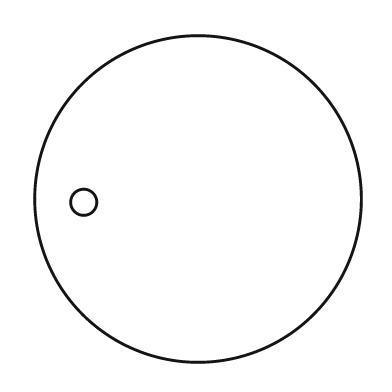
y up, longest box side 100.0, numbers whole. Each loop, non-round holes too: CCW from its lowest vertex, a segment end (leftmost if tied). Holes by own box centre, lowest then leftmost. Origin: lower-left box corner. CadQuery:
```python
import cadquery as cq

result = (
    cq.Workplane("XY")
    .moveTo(50.0, 50.0)
    .circle(50.0)
    .moveTo(15.0, 49.0)
    .circle(4.0)
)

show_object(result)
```